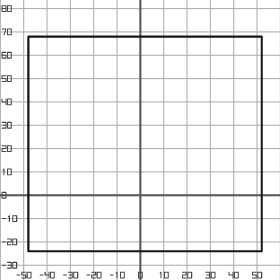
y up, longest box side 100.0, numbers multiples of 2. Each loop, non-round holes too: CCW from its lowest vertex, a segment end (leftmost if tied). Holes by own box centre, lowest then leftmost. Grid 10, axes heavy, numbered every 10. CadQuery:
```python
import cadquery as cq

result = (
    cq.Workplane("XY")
    .moveTo(-48.0, -24.0)
    .lineTo(52.0, -24.0)
    .lineTo(52.0, 68.0)
    .lineTo(-48.0, 68.0)
    .close()
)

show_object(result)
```